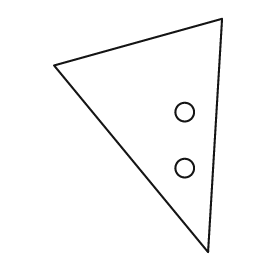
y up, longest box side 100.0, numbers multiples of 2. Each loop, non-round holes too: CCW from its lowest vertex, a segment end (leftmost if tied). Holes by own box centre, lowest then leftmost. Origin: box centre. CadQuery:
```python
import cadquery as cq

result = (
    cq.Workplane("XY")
    .moveTo(30.0, -50.0)
    .lineTo(36.0, 50.0)
    .lineTo(-36.0, 30.0)
    .close()
    .moveTo(20.0, -14.0)
    .circle(4.0)
    .moveTo(20.0, 10.0)
    .circle(4.0)
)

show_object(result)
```